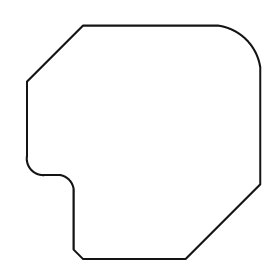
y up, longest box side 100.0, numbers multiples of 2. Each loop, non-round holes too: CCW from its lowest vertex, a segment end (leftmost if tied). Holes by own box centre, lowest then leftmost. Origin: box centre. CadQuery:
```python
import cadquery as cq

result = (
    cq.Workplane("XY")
    .moveTo(-26.0, -50.0)
    .lineTo(18.0, -50.0)
    .lineTo(50.0, -18.0)
    .lineTo(50.0, 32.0)
    .threePointArc((44.0, 44.0), (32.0, 50.0))
    .lineTo(-26.0, 50.0)
    .lineTo(-50.0, 26.0)
    .lineTo(-50.0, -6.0)
    .threePointArc((-48.0, -12.0), (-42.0, -14.0))
    .lineTo(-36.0, -14.0)
    .threePointArc((-32.0, -16.0), (-30.0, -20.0))
    .lineTo(-30.0, -46.0)
    .close()
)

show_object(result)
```